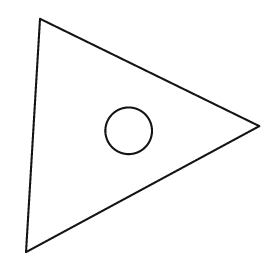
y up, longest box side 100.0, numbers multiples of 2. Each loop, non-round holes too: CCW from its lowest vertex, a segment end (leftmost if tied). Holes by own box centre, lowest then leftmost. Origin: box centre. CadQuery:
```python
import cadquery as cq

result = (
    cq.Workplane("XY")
    .moveTo(-50.0, -50.0)
    .lineTo(50.0, 4.0)
    .lineTo(-44.0, 50.0)
    .close()
    .moveTo(-6.0, 2.0)
    .circle(10.0)
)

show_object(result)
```